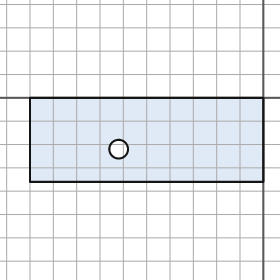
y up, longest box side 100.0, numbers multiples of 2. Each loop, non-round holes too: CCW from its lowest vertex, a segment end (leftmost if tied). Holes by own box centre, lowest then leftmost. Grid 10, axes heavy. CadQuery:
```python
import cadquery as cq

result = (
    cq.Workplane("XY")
    .moveTo(-100.0, -36.0)
    .lineTo(0.0, -36.0)
    .lineTo(0.0, 0.0)
    .lineTo(-100.0, 0.0)
    .close()
    .moveTo(-62.0, -22.0)
    .circle(4.0)
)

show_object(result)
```